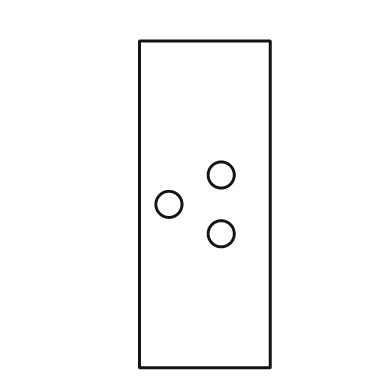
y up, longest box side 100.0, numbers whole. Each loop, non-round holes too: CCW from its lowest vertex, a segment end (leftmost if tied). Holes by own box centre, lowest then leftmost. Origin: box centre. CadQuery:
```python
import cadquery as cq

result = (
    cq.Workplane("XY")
    .moveTo(-20.0, -50.0)
    .lineTo(20.0, -50.0)
    .lineTo(20.0, 50.0)
    .lineTo(-20.0, 50.0)
    .close()
    .moveTo(5.0, -9.0)
    .circle(4.0)
    .moveTo(-11.0, 0.0)
    .circle(4.0)
    .moveTo(5.0, 9.0)
    .circle(4.0)
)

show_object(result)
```